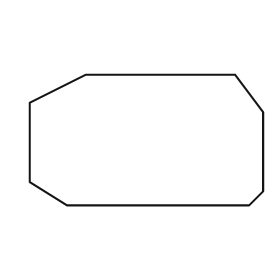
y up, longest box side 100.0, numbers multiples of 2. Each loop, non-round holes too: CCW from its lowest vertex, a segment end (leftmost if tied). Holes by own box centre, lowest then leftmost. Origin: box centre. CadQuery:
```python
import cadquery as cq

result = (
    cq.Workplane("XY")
    .moveTo(-34.0, -28.0)
    .lineTo(44.0, -28.0)
    .lineTo(50.0, -22.0)
    .lineTo(50.0, 12.0)
    .lineTo(38.0, 28.0)
    .lineTo(-26.0, 28.0)
    .lineTo(-50.0, 16.0)
    .lineTo(-50.0, -18.0)
    .close()
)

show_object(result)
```